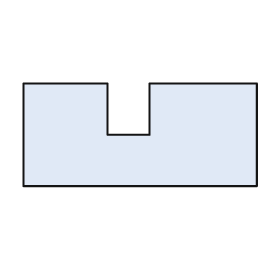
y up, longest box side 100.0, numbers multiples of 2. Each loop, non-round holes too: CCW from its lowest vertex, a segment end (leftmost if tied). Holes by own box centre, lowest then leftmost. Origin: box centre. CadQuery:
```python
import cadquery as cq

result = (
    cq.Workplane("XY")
    .moveTo(-50.0, -22.0)
    .lineTo(50.0, -22.0)
    .lineTo(50.0, 22.0)
    .lineTo(4.0, 22.0)
    .lineTo(4.0, 0.0)
    .lineTo(-14.0, 0.0)
    .lineTo(-14.0, 22.0)
    .lineTo(-50.0, 22.0)
    .close()
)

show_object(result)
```